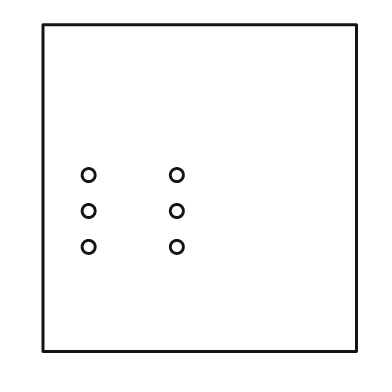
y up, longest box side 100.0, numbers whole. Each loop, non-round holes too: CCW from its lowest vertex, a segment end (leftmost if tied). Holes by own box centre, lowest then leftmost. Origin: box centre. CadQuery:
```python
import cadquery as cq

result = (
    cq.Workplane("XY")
    .moveTo(-48.0, -50.0)
    .lineTo(48.0, -50.0)
    .lineTo(48.0, 50.0)
    .lineTo(-48.0, 50.0)
    .close()
    .moveTo(-34.0, -18.0)
    .circle(2.0)
    .moveTo(-7.0, -18.0)
    .circle(2.0)
    .moveTo(-34.0, -7.0)
    .circle(2.0)
    .moveTo(-7.0, -7.0)
    .circle(2.0)
    .moveTo(-34.0, 4.0)
    .circle(2.0)
    .moveTo(-7.0, 4.0)
    .circle(2.0)
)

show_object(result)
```